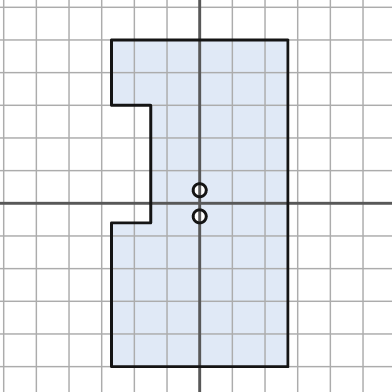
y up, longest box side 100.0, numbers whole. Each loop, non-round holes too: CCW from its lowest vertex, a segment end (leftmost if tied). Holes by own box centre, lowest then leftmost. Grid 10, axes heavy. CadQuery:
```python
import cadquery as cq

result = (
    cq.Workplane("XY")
    .moveTo(-27.0, -50.0)
    .lineTo(27.0, -50.0)
    .lineTo(27.0, 50.0)
    .lineTo(-27.0, 50.0)
    .lineTo(-27.0, 30.0)
    .lineTo(-15.0, 30.0)
    .lineTo(-15.0, -6.0)
    .lineTo(-27.0, -6.0)
    .close()
    .moveTo(0.0, -4.0)
    .circle(2.0)
    .moveTo(0.0, 4.0)
    .circle(2.0)
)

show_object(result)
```